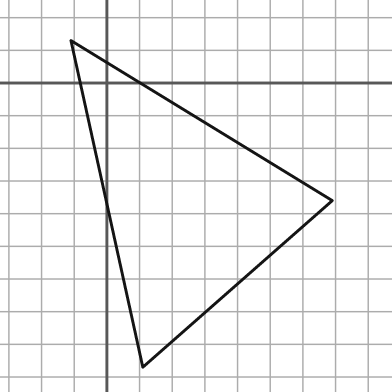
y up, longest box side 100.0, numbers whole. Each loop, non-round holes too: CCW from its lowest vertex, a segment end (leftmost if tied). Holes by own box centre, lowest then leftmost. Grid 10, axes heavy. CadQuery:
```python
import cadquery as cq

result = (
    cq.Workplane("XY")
    .moveTo(11.0, -87.0)
    .lineTo(69.0, -36.0)
    .lineTo(-11.0, 13.0)
    .close()
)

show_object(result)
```